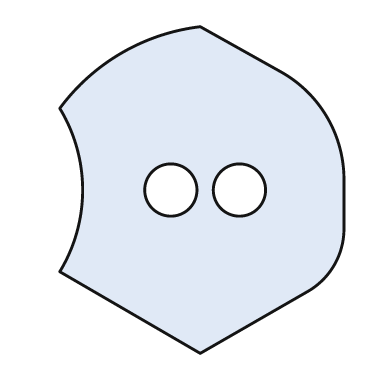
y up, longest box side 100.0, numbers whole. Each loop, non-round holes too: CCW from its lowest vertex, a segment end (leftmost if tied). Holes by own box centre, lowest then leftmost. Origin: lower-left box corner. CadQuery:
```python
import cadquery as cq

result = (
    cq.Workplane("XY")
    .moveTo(43.0, 0.0)
    .lineTo(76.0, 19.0)
    .threePointArc((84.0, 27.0), (87.0, 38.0))
    .lineTo(87.0, 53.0)
    .threePointArc((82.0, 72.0), (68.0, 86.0))
    .lineTo(43.0, 100.0)
    .threePointArc((19.0, 92.0), (0.0, 75.0))
    .threePointArc((7.0, 50.0), (0.0, 25.0))
    .close()
    .moveTo(34.0, 50.0)
    .circle(8.0)
    .moveTo(55.0, 50.0)
    .circle(8.0)
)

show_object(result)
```